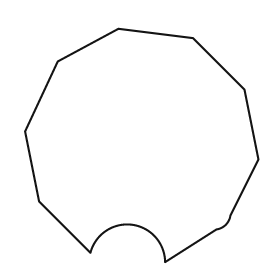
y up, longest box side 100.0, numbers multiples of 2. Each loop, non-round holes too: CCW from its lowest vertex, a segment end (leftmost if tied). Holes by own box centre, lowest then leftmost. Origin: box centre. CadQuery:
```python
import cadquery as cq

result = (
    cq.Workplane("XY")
    .moveTo(10.0, -50.0)
    .lineTo(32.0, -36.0)
    .threePointArc((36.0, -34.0), (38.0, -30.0))
    .lineTo(50.0, -6.0)
    .lineTo(44.0, 24.0)
    .lineTo(22.0, 46.0)
    .lineTo(-10.0, 50.0)
    .lineTo(-36.0, 36.0)
    .lineTo(-50.0, 6.0)
    .lineTo(-44.0, -24.0)
    .lineTo(-22.0, -46.0)
    .threePointArc((-4.0, -34.0), (10.0, -50.0))
    .close()
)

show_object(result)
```